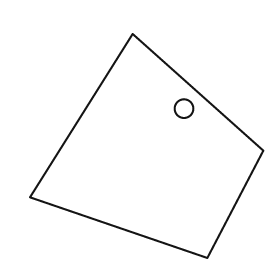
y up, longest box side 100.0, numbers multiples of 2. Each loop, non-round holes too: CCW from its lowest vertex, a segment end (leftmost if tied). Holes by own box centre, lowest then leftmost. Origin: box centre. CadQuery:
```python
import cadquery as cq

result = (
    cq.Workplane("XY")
    .moveTo(26.0, -48.0)
    .lineTo(50.0, -2.0)
    .lineTo(-6.0, 48.0)
    .lineTo(-50.0, -22.0)
    .close()
    .moveTo(16.0, 16.0)
    .circle(4.0)
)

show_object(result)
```